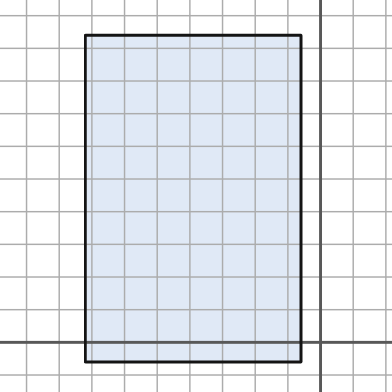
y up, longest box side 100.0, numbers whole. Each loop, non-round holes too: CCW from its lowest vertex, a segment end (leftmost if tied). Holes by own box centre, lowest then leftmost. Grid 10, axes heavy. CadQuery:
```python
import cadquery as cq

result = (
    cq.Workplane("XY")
    .moveTo(-72.0, -6.0)
    .lineTo(-6.0, -6.0)
    .lineTo(-6.0, 94.0)
    .lineTo(-72.0, 94.0)
    .close()
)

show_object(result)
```